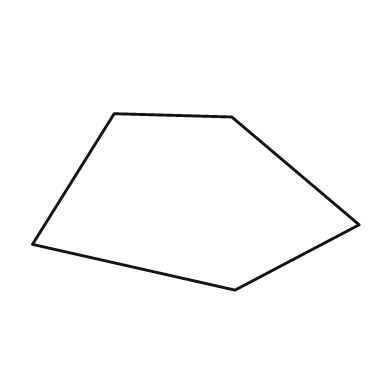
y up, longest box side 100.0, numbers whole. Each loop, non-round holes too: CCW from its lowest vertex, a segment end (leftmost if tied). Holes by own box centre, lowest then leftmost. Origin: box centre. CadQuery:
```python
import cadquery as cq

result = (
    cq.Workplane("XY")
    .moveTo(12.0, -27.0)
    .lineTo(50.0, -7.0)
    .lineTo(11.0, 26.0)
    .lineTo(-25.0, 27.0)
    .lineTo(-50.0, -13.0)
    .close()
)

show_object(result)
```